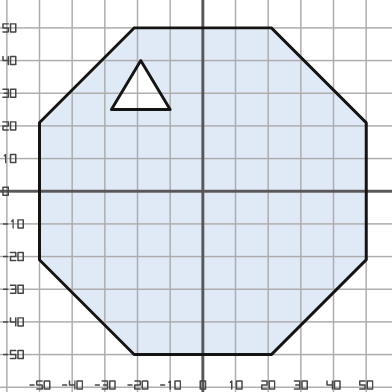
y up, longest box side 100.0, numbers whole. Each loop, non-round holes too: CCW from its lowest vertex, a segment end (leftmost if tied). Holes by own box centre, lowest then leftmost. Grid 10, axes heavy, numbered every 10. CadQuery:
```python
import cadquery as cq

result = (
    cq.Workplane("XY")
    .moveTo(-21.0, -50.0)
    .lineTo(21.0, -50.0)
    .lineTo(50.0, -21.0)
    .lineTo(50.0, 21.0)
    .lineTo(21.0, 50.0)
    .lineTo(-21.0, 50.0)
    .lineTo(-50.0, 21.0)
    .lineTo(-50.0, -21.0)
    .close()
    .moveTo(-28.0, 25.0)
    .lineTo(-10.0, 25.0)
    .lineTo(-19.0, 40.0)
    .close()
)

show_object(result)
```